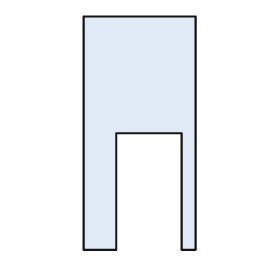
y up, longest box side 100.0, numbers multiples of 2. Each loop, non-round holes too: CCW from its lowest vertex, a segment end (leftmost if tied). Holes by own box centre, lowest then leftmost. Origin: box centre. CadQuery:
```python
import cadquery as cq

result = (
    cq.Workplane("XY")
    .moveTo(-24.0, -50.0)
    .lineTo(-10.0, -50.0)
    .lineTo(-10.0, 0.0)
    .lineTo(18.0, 0.0)
    .lineTo(18.0, -50.0)
    .lineTo(24.0, -50.0)
    .lineTo(24.0, 50.0)
    .lineTo(-24.0, 50.0)
    .close()
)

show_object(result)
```